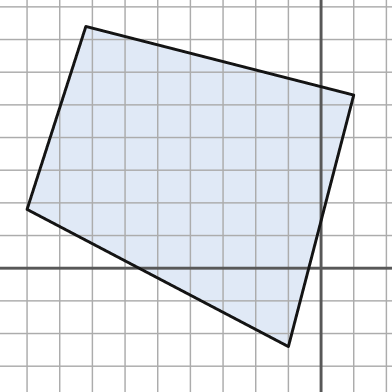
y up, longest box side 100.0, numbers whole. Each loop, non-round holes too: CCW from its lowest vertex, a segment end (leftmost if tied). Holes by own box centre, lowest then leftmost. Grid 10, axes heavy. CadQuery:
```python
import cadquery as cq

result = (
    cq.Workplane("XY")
    .moveTo(-10.0, -24.0)
    .lineTo(10.0, 53.0)
    .lineTo(-72.0, 74.0)
    .lineTo(-90.0, 18.0)
    .close()
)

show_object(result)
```